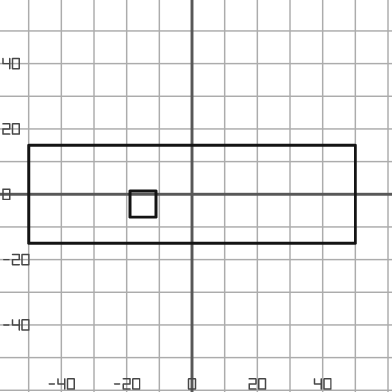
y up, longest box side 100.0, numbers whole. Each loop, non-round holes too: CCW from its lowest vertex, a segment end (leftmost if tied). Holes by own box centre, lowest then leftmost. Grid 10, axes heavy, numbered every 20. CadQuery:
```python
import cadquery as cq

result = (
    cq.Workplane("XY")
    .moveTo(-50.0, -15.0)
    .lineTo(50.0, -15.0)
    .lineTo(50.0, 15.0)
    .lineTo(-50.0, 15.0)
    .close()
    .moveTo(-19.0, -7.0)
    .lineTo(-11.0, -7.0)
    .lineTo(-11.0, 1.0)
    .lineTo(-19.0, 1.0)
    .close()
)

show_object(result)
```